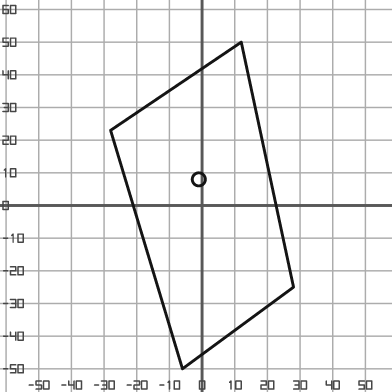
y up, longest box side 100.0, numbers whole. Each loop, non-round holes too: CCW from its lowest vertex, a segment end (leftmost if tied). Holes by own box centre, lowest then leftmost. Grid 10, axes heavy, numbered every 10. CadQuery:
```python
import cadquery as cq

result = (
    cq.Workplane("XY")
    .moveTo(-6.0, -50.0)
    .lineTo(28.0, -25.0)
    .lineTo(12.0, 50.0)
    .lineTo(-28.0, 23.0)
    .close()
    .moveTo(-1.0, 8.0)
    .circle(2.0)
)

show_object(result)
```